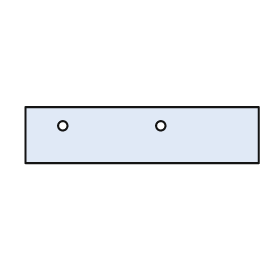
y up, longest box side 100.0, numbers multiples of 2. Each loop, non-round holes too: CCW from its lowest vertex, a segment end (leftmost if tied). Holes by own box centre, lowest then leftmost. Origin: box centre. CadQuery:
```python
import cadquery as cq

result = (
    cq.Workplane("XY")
    .moveTo(-50.0, -12.0)
    .lineTo(50.0, -12.0)
    .lineTo(50.0, 12.0)
    .lineTo(-50.0, 12.0)
    .close()
    .moveTo(-34.0, 4.0)
    .circle(2.0)
    .moveTo(8.0, 4.0)
    .circle(2.0)
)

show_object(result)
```